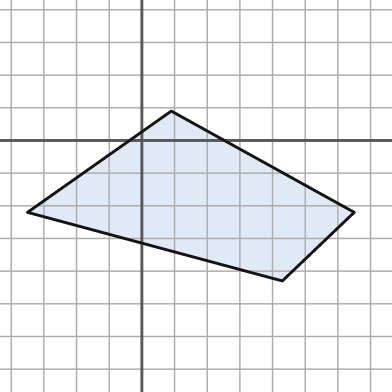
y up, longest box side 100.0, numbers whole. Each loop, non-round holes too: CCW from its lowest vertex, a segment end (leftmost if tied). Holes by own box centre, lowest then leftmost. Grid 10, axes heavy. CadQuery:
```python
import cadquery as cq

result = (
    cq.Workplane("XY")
    .moveTo(43.0, -43.0)
    .lineTo(65.0, -22.0)
    .lineTo(9.0, 9.0)
    .lineTo(-35.0, -22.0)
    .close()
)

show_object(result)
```